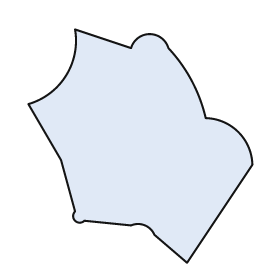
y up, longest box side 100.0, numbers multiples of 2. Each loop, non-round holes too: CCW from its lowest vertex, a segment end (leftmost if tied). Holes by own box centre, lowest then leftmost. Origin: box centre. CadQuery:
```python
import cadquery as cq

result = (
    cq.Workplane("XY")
    .moveTo(20.0, -50.0)
    .lineTo(48.0, -8.0)
    .threePointArc((42.0, 6.0), (28.0, 12.0))
    .threePointArc((22.0, 28.0), (12.0, 42.0))
    .threePointArc((4.0, 48.0), (-4.0, 42.0))
    .lineTo(-28.0, 50.0)
    .threePointArc((-32.0, 30.0), (-48.0, 18.0))
    .lineTo(-34.0, -6.0)
    .lineTo(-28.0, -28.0)
    .threePointArc((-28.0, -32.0), (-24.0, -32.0))
    .lineTo(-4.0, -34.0)
    .threePointArc((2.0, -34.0), (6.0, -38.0))
    .close()
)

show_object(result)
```